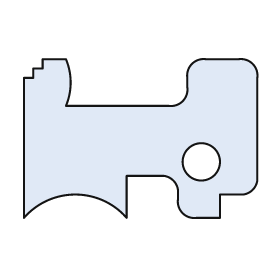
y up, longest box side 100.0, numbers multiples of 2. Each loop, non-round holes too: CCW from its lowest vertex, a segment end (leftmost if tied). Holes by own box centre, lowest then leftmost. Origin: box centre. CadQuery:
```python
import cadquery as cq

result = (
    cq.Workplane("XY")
    .moveTo(-50.0, -34.0)
    .threePointArc((-28.0, -24.0), (-6.0, -34.0))
    .lineTo(-6.0, -16.0)
    .lineTo(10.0, -16.0)
    .threePointArc((14.0, -18.0), (16.0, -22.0))
    .lineTo(16.0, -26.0)
    .threePointArc((18.0, -32.0), (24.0, -34.0))
    .lineTo(34.0, -34.0)
    .lineTo(34.0, -24.0)
    .lineTo(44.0, -24.0)
    .threePointArc((48.0, -22.0), (50.0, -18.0))
    .lineTo(50.0, 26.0)
    .threePointArc((48.0, 32.0), (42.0, 34.0))
    .lineTo(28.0, 34.0)
    .threePointArc((22.0, 32.0), (20.0, 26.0))
    .lineTo(20.0, 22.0)
    .threePointArc((18.0, 16.0), (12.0, 14.0))
    .lineTo(-32.0, 14.0)
    .threePointArc((-30.0, 24.0), (-32.0, 34.0))
    .lineTo(-42.0, 34.0)
    .lineTo(-42.0, 30.0)
    .lineTo(-46.0, 30.0)
    .lineTo(-46.0, 26.0)
    .lineTo(-50.0, 26.0)
    .close()
    .moveTo(26.0, -10.0)
    .circle(8.0)
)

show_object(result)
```